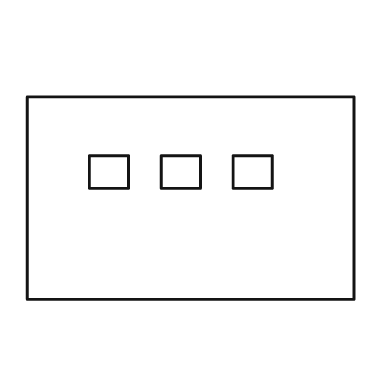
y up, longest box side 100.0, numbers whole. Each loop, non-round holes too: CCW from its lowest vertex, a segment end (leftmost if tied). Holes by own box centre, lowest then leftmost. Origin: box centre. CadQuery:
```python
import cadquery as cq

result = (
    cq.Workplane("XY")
    .moveTo(-50.0, -31.0)
    .lineTo(50.0, -31.0)
    .lineTo(50.0, 31.0)
    .lineTo(-50.0, 31.0)
    .close()
    .moveTo(-31.0, 3.0)
    .lineTo(-19.0, 3.0)
    .lineTo(-19.0, 13.0)
    .lineTo(-31.0, 13.0)
    .close()
    .moveTo(-9.0, 3.0)
    .lineTo(3.0, 3.0)
    .lineTo(3.0, 13.0)
    .lineTo(-9.0, 13.0)
    .close()
    .moveTo(13.0, 3.0)
    .lineTo(25.0, 3.0)
    .lineTo(25.0, 13.0)
    .lineTo(13.0, 13.0)
    .close()
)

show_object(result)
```